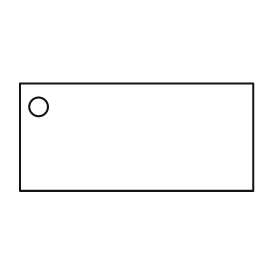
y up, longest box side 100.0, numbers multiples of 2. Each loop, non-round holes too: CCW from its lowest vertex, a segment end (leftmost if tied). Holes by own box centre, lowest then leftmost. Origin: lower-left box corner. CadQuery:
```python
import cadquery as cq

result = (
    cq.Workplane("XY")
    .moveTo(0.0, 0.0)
    .lineTo(100.0, 0.0)
    .lineTo(100.0, 46.0)
    .lineTo(0.0, 46.0)
    .close()
    .moveTo(8.0, 36.0)
    .circle(4.0)
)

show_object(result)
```